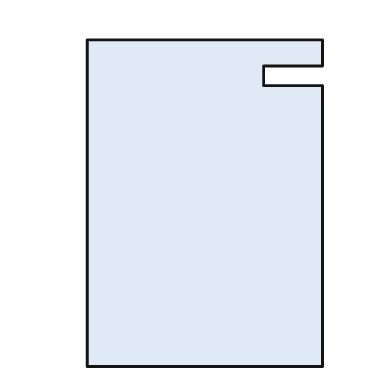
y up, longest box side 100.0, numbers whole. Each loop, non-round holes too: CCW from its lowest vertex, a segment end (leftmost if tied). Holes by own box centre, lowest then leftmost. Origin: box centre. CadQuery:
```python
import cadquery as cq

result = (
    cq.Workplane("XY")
    .moveTo(-36.0, -50.0)
    .lineTo(36.0, -50.0)
    .lineTo(36.0, 36.0)
    .lineTo(18.0, 36.0)
    .lineTo(18.0, 42.0)
    .lineTo(36.0, 42.0)
    .lineTo(36.0, 50.0)
    .lineTo(-36.0, 50.0)
    .close()
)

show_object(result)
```